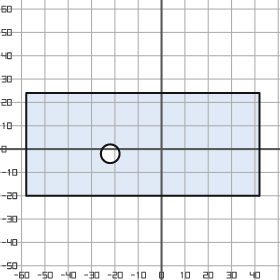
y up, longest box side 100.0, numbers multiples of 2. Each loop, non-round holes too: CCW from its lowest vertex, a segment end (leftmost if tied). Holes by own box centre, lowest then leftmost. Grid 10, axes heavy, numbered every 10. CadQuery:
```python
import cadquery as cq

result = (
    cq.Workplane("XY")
    .moveTo(-58.0, -20.0)
    .lineTo(42.0, -20.0)
    .lineTo(42.0, 24.0)
    .lineTo(-58.0, 24.0)
    .close()
    .moveTo(-22.0, -2.0)
    .circle(4.0)
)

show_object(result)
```